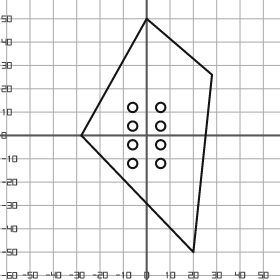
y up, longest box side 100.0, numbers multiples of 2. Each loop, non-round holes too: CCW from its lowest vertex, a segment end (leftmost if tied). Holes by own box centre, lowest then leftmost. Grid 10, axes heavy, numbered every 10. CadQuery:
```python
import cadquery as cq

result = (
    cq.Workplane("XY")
    .moveTo(20.0, -50.0)
    .lineTo(28.0, 26.0)
    .lineTo(0.0, 50.0)
    .lineTo(-28.0, 0.0)
    .close()
    .moveTo(-6.0, -12.0)
    .circle(2.0)
    .moveTo(6.0, -12.0)
    .circle(2.0)
    .moveTo(-6.0, -4.0)
    .circle(2.0)
    .moveTo(6.0, -4.0)
    .circle(2.0)
    .moveTo(-6.0, 4.0)
    .circle(2.0)
    .moveTo(6.0, 4.0)
    .circle(2.0)
    .moveTo(-6.0, 12.0)
    .circle(2.0)
    .moveTo(6.0, 12.0)
    .circle(2.0)
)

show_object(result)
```